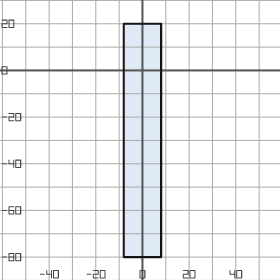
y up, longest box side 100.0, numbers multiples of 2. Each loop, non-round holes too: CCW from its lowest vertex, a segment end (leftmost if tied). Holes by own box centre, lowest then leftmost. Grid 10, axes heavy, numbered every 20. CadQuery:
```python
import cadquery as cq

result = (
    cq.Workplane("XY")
    .moveTo(-8.0, -80.0)
    .lineTo(8.0, -80.0)
    .lineTo(8.0, 20.0)
    .lineTo(-8.0, 20.0)
    .close()
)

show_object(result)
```